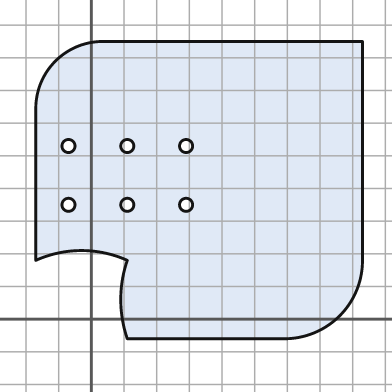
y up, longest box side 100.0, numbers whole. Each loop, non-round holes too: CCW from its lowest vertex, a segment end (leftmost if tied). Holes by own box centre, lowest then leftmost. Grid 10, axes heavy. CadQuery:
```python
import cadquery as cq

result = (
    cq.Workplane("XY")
    .moveTo(11.0, -6.0)
    .lineTo(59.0, -6.0)
    .threePointArc((76.0, 1.0), (83.0, 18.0))
    .lineTo(83.0, 85.0)
    .lineTo(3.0, 85.0)
    .threePointArc((-11.0, 79.0), (-17.0, 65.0))
    .lineTo(-17.0, 18.0)
    .threePointArc((-3.0, 21.0), (11.0, 18.0))
    .threePointArc((9.0, 6.0), (11.0, -6.0))
    .close()
    .moveTo(-7.0, 35.0)
    .circle(2.0)
    .moveTo(11.0, 35.0)
    .circle(2.0)
    .moveTo(29.0, 35.0)
    .circle(2.0)
    .moveTo(-7.0, 53.0)
    .circle(2.0)
    .moveTo(11.0, 53.0)
    .circle(2.0)
    .moveTo(29.0, 53.0)
    .circle(2.0)
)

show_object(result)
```